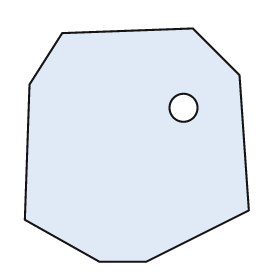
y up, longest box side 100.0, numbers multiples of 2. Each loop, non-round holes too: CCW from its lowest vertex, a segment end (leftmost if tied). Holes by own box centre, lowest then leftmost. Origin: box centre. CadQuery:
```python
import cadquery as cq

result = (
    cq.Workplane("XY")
    .moveTo(-16.0, -50.0)
    .lineTo(4.0, -50.0)
    .lineTo(48.0, -28.0)
    .lineTo(44.0, 30.0)
    .lineTo(24.0, 50.0)
    .lineTo(-32.0, 48.0)
    .lineTo(-46.0, 26.0)
    .lineTo(-48.0, -32.0)
    .close()
    .moveTo(20.0, 16.0)
    .circle(6.0)
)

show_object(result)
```